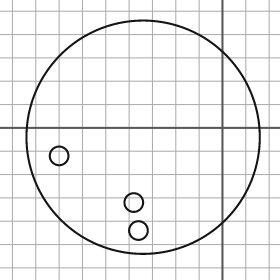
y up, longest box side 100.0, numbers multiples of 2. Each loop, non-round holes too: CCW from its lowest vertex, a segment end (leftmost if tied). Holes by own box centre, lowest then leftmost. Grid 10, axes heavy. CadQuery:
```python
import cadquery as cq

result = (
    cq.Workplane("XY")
    .moveTo(-34.0, -4.0)
    .circle(50.0)
    .moveTo(-36.0, -44.0)
    .circle(4.0)
    .moveTo(-38.0, -32.0)
    .circle(4.0)
    .moveTo(-70.0, -12.0)
    .circle(4.0)
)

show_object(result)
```